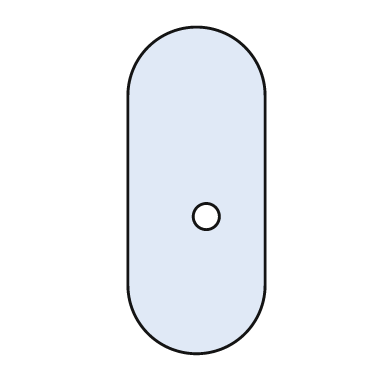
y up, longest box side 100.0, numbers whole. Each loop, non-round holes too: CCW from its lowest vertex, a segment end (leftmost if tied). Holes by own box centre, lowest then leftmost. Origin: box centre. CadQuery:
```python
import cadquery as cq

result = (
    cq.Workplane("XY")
    .moveTo(-21.0, -29.0)
    .threePointArc((0.0, -50.0), (21.0, -29.0))
    .lineTo(21.0, 29.0)
    .threePointArc((0.0, 50.0), (-21.0, 29.0))
    .close()
    .moveTo(3.0, -8.0)
    .circle(4.0)
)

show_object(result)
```